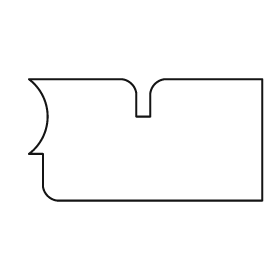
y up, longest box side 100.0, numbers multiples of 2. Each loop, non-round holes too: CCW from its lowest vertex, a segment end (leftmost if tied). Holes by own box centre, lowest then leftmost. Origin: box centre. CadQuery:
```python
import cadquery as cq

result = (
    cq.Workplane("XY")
    .moveTo(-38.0, -26.0)
    .lineTo(50.0, -26.0)
    .lineTo(50.0, 26.0)
    .lineTo(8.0, 26.0)
    .threePointArc((4.0, 24.0), (2.0, 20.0))
    .lineTo(2.0, 10.0)
    .lineTo(-4.0, 10.0)
    .lineTo(-4.0, 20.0)
    .threePointArc((-6.0, 24.0), (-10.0, 26.0))
    .lineTo(-50.0, 26.0)
    .threePointArc((-42.0, 10.0), (-50.0, -6.0))
    .lineTo(-44.0, -6.0)
    .lineTo(-44.0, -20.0)
    .threePointArc((-42.0, -24.0), (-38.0, -26.0))
    .close()
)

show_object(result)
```